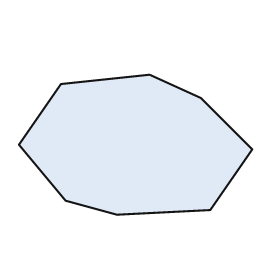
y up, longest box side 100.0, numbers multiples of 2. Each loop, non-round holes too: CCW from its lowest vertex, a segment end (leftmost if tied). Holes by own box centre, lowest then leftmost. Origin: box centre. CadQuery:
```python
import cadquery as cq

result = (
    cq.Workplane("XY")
    .moveTo(-8.0, -30.0)
    .lineTo(32.0, -28.0)
    .lineTo(50.0, -2.0)
    .lineTo(28.0, 20.0)
    .lineTo(6.0, 30.0)
    .lineTo(-32.0, 26.0)
    .lineTo(-50.0, 0.0)
    .lineTo(-30.0, -24.0)
    .close()
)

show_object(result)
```